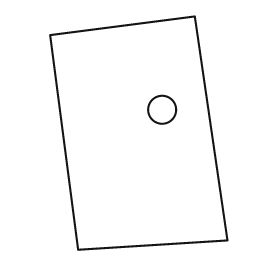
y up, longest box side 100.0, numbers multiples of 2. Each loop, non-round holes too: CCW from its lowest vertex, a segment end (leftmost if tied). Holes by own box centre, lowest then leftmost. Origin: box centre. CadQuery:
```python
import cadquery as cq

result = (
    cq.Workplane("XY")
    .moveTo(-26.0, -50.0)
    .lineTo(38.0, -46.0)
    .lineTo(24.0, 50.0)
    .lineTo(-38.0, 42.0)
    .close()
    .moveTo(10.0, 10.0)
    .circle(6.0)
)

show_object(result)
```